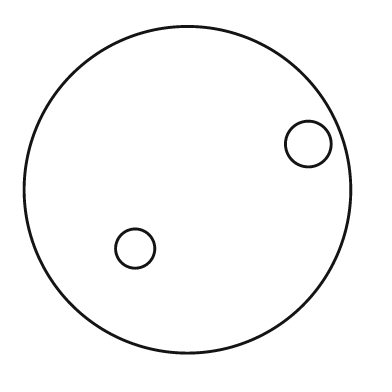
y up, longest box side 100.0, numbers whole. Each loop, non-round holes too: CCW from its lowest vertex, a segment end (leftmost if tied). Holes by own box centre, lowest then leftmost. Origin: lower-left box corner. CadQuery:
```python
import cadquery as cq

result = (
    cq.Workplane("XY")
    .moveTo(50.0, 50.0)
    .circle(50.0)
    .moveTo(34.0, 32.0)
    .circle(6.0)
    .moveTo(87.0, 64.0)
    .circle(7.0)
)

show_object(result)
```